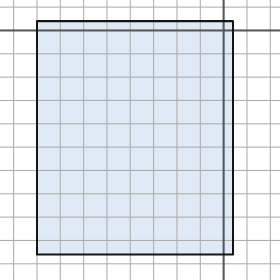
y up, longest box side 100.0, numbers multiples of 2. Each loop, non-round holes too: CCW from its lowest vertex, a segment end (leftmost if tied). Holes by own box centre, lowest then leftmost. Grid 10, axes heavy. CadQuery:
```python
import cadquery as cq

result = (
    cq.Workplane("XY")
    .moveTo(-80.0, -96.0)
    .lineTo(4.0, -96.0)
    .lineTo(4.0, 4.0)
    .lineTo(-80.0, 4.0)
    .close()
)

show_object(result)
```